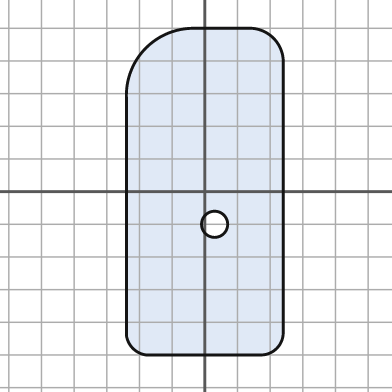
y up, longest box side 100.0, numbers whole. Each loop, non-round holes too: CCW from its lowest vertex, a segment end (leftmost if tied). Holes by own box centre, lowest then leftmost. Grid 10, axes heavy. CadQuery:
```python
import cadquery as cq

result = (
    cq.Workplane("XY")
    .moveTo(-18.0, -50.0)
    .lineTo(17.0, -50.0)
    .threePointArc((22.0, -48.0), (24.0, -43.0))
    .lineTo(24.0, 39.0)
    .threePointArc((21.0, 47.0), (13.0, 50.0))
    .lineTo(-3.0, 50.0)
    .threePointArc((-18.0, 44.0), (-24.0, 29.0))
    .lineTo(-24.0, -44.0)
    .threePointArc((-22.0, -48.0), (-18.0, -50.0))
    .close()
    .moveTo(3.0, -10.0)
    .circle(4.0)
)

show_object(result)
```